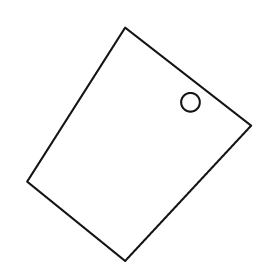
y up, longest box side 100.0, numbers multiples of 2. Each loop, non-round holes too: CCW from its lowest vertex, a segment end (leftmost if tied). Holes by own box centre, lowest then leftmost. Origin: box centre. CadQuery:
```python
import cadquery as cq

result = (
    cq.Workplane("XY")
    .moveTo(-6.0, -50.0)
    .lineTo(48.0, 8.0)
    .lineTo(-6.0, 50.0)
    .lineTo(-48.0, -16.0)
    .close()
    .moveTo(22.0, 18.0)
    .circle(4.0)
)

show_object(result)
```